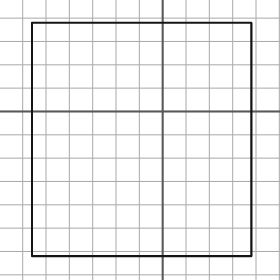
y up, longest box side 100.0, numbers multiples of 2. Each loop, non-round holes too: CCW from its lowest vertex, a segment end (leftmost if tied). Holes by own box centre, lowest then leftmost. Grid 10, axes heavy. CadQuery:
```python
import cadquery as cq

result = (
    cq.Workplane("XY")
    .moveTo(-56.0, -62.0)
    .lineTo(38.0, -62.0)
    .lineTo(38.0, 38.0)
    .lineTo(-56.0, 38.0)
    .close()
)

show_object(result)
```